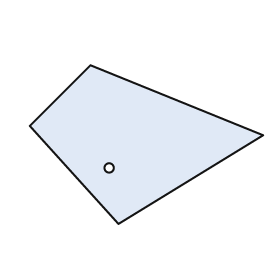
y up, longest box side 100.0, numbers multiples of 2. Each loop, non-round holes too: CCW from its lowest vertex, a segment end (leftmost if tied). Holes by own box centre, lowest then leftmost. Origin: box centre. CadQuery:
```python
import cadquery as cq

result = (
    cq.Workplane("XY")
    .moveTo(-12.0, -34.0)
    .lineTo(50.0, 4.0)
    .lineTo(-24.0, 34.0)
    .lineTo(-50.0, 8.0)
    .close()
    .moveTo(-16.0, -10.0)
    .circle(2.0)
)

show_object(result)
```